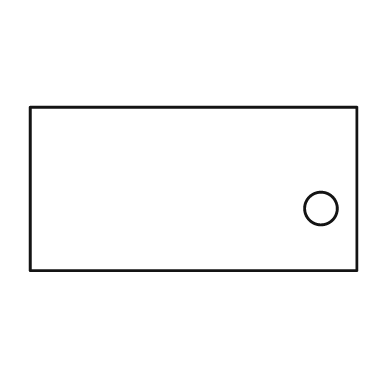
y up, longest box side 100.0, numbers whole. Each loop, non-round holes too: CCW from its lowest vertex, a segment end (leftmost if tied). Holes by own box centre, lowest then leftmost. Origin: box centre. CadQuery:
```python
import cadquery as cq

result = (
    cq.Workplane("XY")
    .moveTo(-50.0, -25.0)
    .lineTo(50.0, -25.0)
    .lineTo(50.0, 25.0)
    .lineTo(-50.0, 25.0)
    .close()
    .moveTo(39.0, -6.0)
    .circle(5.0)
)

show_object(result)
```